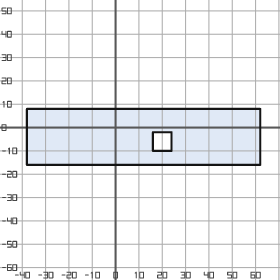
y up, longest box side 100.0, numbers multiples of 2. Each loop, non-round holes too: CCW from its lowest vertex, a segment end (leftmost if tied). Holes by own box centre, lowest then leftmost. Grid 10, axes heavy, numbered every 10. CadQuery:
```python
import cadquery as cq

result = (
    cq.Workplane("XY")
    .moveTo(-38.0, -16.0)
    .lineTo(62.0, -16.0)
    .lineTo(62.0, 8.0)
    .lineTo(-38.0, 8.0)
    .close()
    .moveTo(16.0, -10.0)
    .lineTo(24.0, -10.0)
    .lineTo(24.0, -2.0)
    .lineTo(16.0, -2.0)
    .close()
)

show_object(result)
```